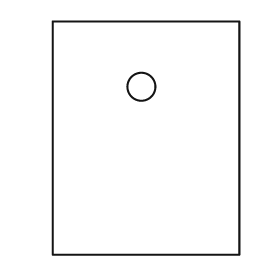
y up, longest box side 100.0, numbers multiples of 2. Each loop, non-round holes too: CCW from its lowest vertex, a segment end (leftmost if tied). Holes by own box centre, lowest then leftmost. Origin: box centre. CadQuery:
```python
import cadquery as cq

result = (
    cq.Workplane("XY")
    .moveTo(-40.0, -50.0)
    .lineTo(40.0, -50.0)
    .lineTo(40.0, 50.0)
    .lineTo(-40.0, 50.0)
    .close()
    .moveTo(-2.0, 22.0)
    .circle(6.0)
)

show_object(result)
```